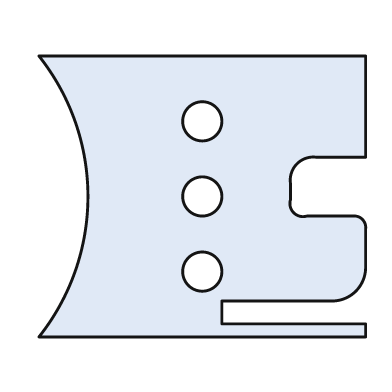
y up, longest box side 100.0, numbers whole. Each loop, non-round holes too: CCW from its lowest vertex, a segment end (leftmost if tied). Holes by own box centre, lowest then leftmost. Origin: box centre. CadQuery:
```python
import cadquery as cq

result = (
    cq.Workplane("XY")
    .moveTo(-50.0, -43.0)
    .lineTo(50.0, -43.0)
    .lineTo(50.0, -39.0)
    .lineTo(6.0, -39.0)
    .lineTo(6.0, -32.0)
    .lineTo(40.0, -32.0)
    .threePointArc((47.0, -29.0), (50.0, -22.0))
    .lineTo(50.0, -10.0)
    .threePointArc((49.0, -7.0), (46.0, -6.0))
    .lineTo(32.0, -6.0)
    .threePointArc((28.0, -5.0), (27.0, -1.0))
    .lineTo(27.0, 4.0)
    .threePointArc((29.0, 10.0), (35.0, 12.0))
    .lineTo(50.0, 12.0)
    .lineTo(50.0, 43.0)
    .lineTo(-50.0, 43.0)
    .threePointArc((-35.0, 0.0), (-50.0, -43.0))
    .close()
    .moveTo(0.0, -23.0)
    .circle(6.0)
    .moveTo(0.0, 0.0)
    .circle(6.0)
    .moveTo(0.0, 23.0)
    .circle(6.0)
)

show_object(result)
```